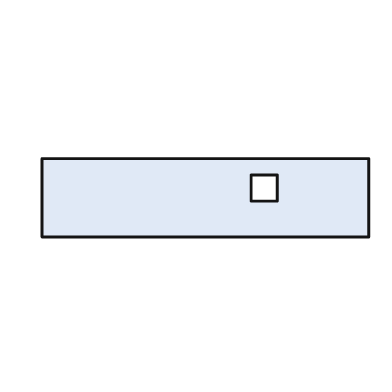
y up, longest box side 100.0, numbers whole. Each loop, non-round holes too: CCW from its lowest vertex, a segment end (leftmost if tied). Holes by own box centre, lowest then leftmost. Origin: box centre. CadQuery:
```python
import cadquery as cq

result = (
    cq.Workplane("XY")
    .moveTo(-50.0, -12.0)
    .lineTo(50.0, -12.0)
    .lineTo(50.0, 12.0)
    .lineTo(-50.0, 12.0)
    .close()
    .moveTo(14.0, -1.0)
    .lineTo(22.0, -1.0)
    .lineTo(22.0, 7.0)
    .lineTo(14.0, 7.0)
    .close()
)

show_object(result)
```